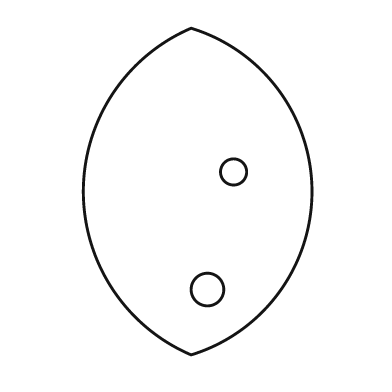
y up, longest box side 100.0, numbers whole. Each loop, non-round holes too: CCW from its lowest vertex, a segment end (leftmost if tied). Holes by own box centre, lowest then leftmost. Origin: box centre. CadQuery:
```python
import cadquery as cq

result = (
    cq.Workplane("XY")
    .moveTo(-2.0, -50.0)
    .threePointArc((35.0, 0.0), (-2.0, 50.0))
    .threePointArc((-35.0, 0.0), (-2.0, -50.0))
    .close()
    .moveTo(3.0, -30.0)
    .circle(5.0)
    .moveTo(11.0, 6.0)
    .circle(4.0)
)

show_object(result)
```